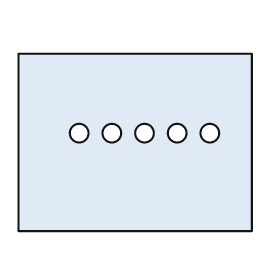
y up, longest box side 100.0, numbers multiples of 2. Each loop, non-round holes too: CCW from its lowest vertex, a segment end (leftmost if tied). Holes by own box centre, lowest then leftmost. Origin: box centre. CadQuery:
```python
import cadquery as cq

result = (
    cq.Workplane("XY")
    .moveTo(-50.0, -38.0)
    .lineTo(50.0, -38.0)
    .lineTo(50.0, 38.0)
    .lineTo(-50.0, 38.0)
    .close()
    .moveTo(-24.0, 4.0)
    .circle(4.0)
    .moveTo(-10.0, 4.0)
    .circle(4.0)
    .moveTo(4.0, 4.0)
    .circle(4.0)
    .moveTo(18.0, 4.0)
    .circle(4.0)
    .moveTo(32.0, 4.0)
    .circle(4.0)
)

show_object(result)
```